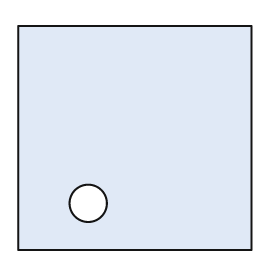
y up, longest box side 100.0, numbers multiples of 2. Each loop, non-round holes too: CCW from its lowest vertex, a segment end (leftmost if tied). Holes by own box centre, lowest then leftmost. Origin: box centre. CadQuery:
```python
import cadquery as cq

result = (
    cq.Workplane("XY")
    .moveTo(-50.0, -48.0)
    .lineTo(50.0, -48.0)
    .lineTo(50.0, 48.0)
    .lineTo(-50.0, 48.0)
    .close()
    .moveTo(-20.0, -28.0)
    .circle(8.0)
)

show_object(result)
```